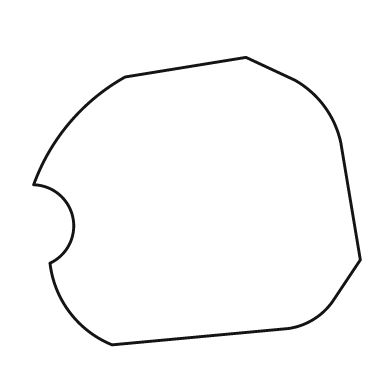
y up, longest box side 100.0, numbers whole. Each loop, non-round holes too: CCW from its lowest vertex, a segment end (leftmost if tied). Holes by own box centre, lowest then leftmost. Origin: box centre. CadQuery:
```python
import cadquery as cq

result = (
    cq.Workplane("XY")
    .moveTo(-26.0, -44.0)
    .lineTo(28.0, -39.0)
    .threePointArc((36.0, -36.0), (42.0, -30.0))
    .lineTo(50.0, -18.0)
    .lineTo(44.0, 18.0)
    .threePointArc((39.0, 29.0), (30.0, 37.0))
    .lineTo(15.0, 44.0)
    .lineTo(-22.0, 38.0)
    .threePointArc((-39.0, 24.0), (-50.0, 5.0))
    .threePointArc((-38.0, -5.0), (-45.0, -19.0))
    .threePointArc((-39.0, -34.0), (-26.0, -44.0))
    .close()
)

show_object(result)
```